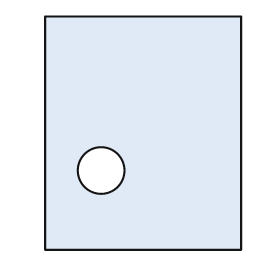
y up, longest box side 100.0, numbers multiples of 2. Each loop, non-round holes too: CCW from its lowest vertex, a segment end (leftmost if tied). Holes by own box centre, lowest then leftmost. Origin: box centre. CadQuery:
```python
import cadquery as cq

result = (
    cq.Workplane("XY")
    .moveTo(-42.0, -50.0)
    .lineTo(42.0, -50.0)
    .lineTo(42.0, 50.0)
    .lineTo(-42.0, 50.0)
    .close()
    .moveTo(-18.0, -16.0)
    .circle(10.0)
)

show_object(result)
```